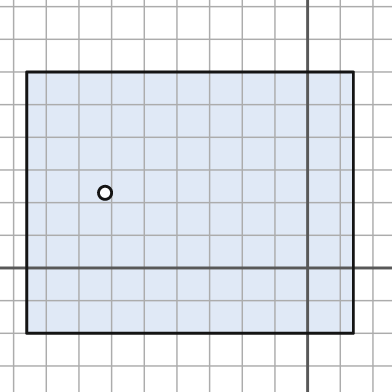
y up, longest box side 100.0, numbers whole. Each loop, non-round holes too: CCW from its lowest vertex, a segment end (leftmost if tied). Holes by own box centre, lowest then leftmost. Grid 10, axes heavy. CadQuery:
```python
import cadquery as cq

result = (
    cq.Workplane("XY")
    .moveTo(-86.0, -20.0)
    .lineTo(14.0, -20.0)
    .lineTo(14.0, 60.0)
    .lineTo(-86.0, 60.0)
    .close()
    .moveTo(-62.0, 23.0)
    .circle(2.0)
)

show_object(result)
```